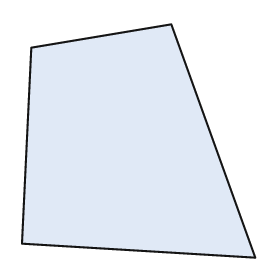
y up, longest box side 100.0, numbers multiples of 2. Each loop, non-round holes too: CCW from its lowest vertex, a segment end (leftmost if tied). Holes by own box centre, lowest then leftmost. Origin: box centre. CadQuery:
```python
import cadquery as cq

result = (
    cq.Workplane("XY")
    .moveTo(50.0, -50.0)
    .lineTo(14.0, 50.0)
    .lineTo(-46.0, 40.0)
    .lineTo(-50.0, -44.0)
    .close()
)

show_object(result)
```